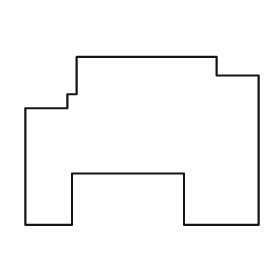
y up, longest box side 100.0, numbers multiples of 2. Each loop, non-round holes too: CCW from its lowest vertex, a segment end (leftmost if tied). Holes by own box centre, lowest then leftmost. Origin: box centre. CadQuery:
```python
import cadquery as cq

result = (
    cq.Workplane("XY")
    .moveTo(-50.0, -36.0)
    .lineTo(-30.0, -36.0)
    .lineTo(-30.0, -14.0)
    .lineTo(18.0, -14.0)
    .lineTo(18.0, -36.0)
    .lineTo(50.0, -36.0)
    .lineTo(50.0, 28.0)
    .lineTo(32.0, 28.0)
    .lineTo(32.0, 36.0)
    .lineTo(-28.0, 36.0)
    .lineTo(-28.0, 20.0)
    .lineTo(-32.0, 20.0)
    .lineTo(-32.0, 14.0)
    .lineTo(-50.0, 14.0)
    .close()
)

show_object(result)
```